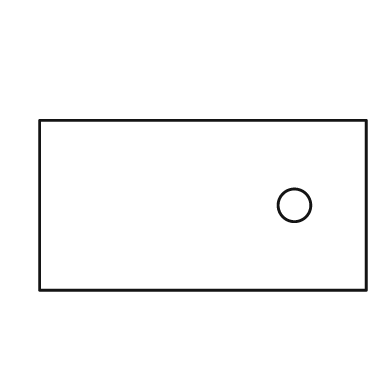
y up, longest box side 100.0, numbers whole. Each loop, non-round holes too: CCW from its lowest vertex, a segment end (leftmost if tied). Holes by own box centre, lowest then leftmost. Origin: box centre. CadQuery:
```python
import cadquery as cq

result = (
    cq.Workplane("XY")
    .moveTo(-50.0, -26.0)
    .lineTo(50.0, -26.0)
    .lineTo(50.0, 26.0)
    .lineTo(-50.0, 26.0)
    .close()
    .moveTo(28.0, 0.0)
    .circle(5.0)
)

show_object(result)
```